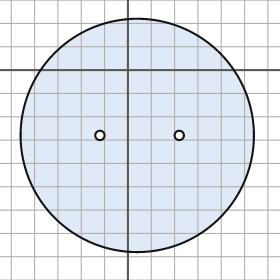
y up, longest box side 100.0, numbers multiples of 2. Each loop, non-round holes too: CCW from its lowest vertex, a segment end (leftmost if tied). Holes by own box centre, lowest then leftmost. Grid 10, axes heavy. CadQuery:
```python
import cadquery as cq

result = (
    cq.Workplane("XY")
    .moveTo(4.0, -28.0)
    .circle(50.0)
    .moveTo(-12.0, -28.0)
    .circle(2.0)
    .moveTo(22.0, -28.0)
    .circle(2.0)
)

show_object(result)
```